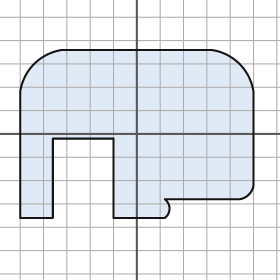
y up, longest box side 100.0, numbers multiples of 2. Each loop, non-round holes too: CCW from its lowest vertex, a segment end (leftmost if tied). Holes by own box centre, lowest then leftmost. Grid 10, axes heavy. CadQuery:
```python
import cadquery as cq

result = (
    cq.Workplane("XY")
    .moveTo(-50.0, -36.0)
    .lineTo(-36.0, -36.0)
    .lineTo(-36.0, -2.0)
    .lineTo(-10.0, -2.0)
    .lineTo(-10.0, -36.0)
    .lineTo(12.0, -36.0)
    .threePointArc((14.0, -32.0), (12.0, -28.0))
    .lineTo(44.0, -28.0)
    .threePointArc((48.0, -26.0), (50.0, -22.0))
    .lineTo(50.0, 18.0)
    .threePointArc((44.0, 30.0), (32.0, 36.0))
    .lineTo(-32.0, 36.0)
    .threePointArc((-44.0, 30.0), (-50.0, 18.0))
    .close()
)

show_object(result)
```